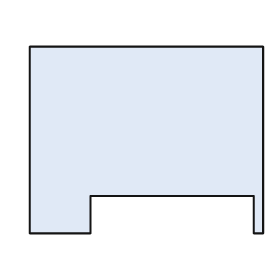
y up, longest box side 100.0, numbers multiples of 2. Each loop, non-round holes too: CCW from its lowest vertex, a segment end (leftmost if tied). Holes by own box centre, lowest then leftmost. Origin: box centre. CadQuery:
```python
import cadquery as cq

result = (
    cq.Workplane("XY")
    .moveTo(-50.0, -40.0)
    .lineTo(-24.0, -40.0)
    .lineTo(-24.0, -24.0)
    .lineTo(46.0, -24.0)
    .lineTo(46.0, -40.0)
    .lineTo(50.0, -40.0)
    .lineTo(50.0, 40.0)
    .lineTo(-50.0, 40.0)
    .close()
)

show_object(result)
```